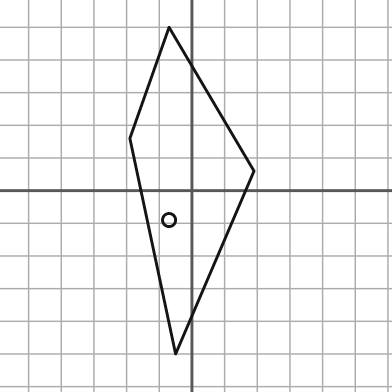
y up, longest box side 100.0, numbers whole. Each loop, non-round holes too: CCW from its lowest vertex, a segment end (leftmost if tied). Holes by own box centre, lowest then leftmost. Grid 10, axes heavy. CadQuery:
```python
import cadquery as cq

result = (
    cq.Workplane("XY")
    .moveTo(-5.0, -50.0)
    .lineTo(19.0, 6.0)
    .lineTo(-7.0, 50.0)
    .lineTo(-19.0, 16.0)
    .close()
    .moveTo(-7.0, -9.0)
    .circle(2.0)
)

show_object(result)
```